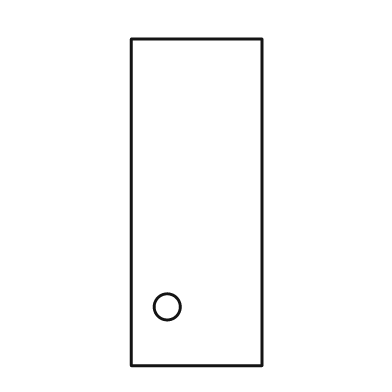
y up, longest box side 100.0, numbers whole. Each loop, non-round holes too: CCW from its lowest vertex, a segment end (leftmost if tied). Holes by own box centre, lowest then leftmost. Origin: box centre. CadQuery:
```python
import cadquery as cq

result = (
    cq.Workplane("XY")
    .moveTo(-20.0, -50.0)
    .lineTo(20.0, -50.0)
    .lineTo(20.0, 50.0)
    .lineTo(-20.0, 50.0)
    .close()
    .moveTo(-9.0, -32.0)
    .circle(4.0)
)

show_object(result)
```